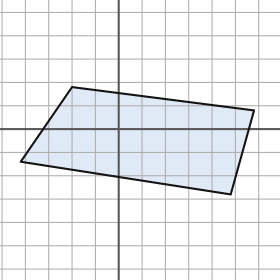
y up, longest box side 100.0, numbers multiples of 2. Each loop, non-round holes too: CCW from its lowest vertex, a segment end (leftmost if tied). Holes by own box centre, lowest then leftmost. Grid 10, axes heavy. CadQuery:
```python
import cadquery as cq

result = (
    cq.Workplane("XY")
    .moveTo(48.0, -28.0)
    .lineTo(58.0, 8.0)
    .lineTo(-20.0, 18.0)
    .lineTo(-42.0, -14.0)
    .close()
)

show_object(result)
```